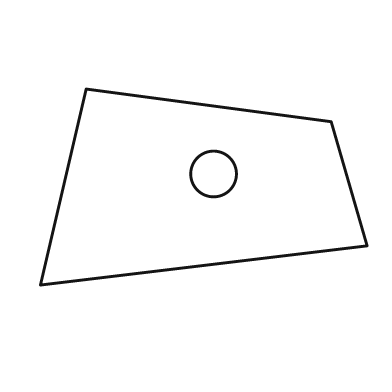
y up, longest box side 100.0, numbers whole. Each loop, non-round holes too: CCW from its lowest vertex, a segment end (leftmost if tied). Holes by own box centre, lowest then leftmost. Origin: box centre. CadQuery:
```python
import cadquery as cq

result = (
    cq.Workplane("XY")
    .moveTo(-50.0, -30.0)
    .lineTo(50.0, -18.0)
    .lineTo(39.0, 20.0)
    .lineTo(-36.0, 30.0)
    .close()
    .moveTo(3.0, 4.0)
    .circle(7.0)
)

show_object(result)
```